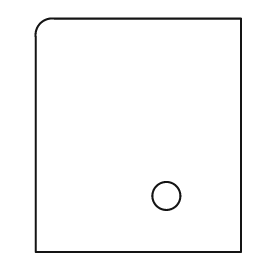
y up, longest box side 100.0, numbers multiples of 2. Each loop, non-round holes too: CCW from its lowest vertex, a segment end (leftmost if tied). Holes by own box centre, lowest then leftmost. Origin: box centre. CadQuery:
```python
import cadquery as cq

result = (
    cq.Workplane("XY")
    .moveTo(-44.0, -50.0)
    .lineTo(44.0, -50.0)
    .lineTo(44.0, 50.0)
    .lineTo(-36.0, 50.0)
    .threePointArc((-42.0, 48.0), (-44.0, 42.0))
    .close()
    .moveTo(12.0, -26.0)
    .circle(6.0)
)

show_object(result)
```